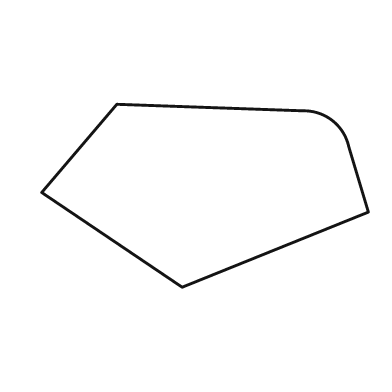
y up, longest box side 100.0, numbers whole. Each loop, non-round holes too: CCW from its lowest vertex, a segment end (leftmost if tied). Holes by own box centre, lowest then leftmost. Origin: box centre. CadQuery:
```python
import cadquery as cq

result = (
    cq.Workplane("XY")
    .moveTo(-7.0, -28.0)
    .lineTo(50.0, -5.0)
    .lineTo(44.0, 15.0)
    .threePointArc((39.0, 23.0), (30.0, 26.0))
    .lineTo(-27.0, 28.0)
    .lineTo(-50.0, 1.0)
    .close()
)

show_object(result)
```